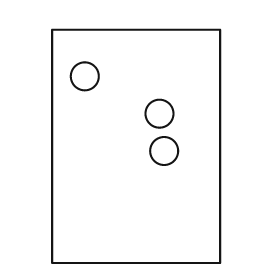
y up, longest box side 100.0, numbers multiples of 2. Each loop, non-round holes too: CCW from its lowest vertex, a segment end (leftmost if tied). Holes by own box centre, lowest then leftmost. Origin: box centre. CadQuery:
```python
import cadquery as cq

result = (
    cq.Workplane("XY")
    .moveTo(-36.0, -50.0)
    .lineTo(36.0, -50.0)
    .lineTo(36.0, 50.0)
    .lineTo(-36.0, 50.0)
    .close()
    .moveTo(12.0, -2.0)
    .circle(6.0)
    .moveTo(10.0, 14.0)
    .circle(6.0)
    .moveTo(-22.0, 30.0)
    .circle(6.0)
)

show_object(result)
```